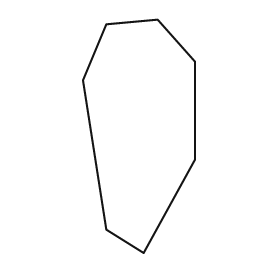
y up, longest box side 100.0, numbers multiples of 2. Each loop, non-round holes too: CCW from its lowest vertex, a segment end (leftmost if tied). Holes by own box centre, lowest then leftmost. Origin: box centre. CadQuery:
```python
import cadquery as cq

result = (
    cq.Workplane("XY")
    .moveTo(2.0, -50.0)
    .lineTo(24.0, -10.0)
    .lineTo(24.0, 32.0)
    .lineTo(8.0, 50.0)
    .lineTo(-14.0, 48.0)
    .lineTo(-24.0, 24.0)
    .lineTo(-14.0, -40.0)
    .close()
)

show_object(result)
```